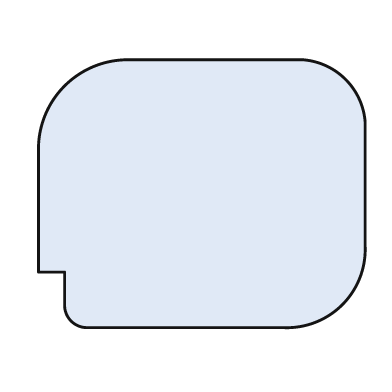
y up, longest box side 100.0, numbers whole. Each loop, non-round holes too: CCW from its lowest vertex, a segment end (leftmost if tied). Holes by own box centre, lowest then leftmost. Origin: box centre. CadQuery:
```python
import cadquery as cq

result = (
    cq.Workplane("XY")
    .moveTo(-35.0, -41.0)
    .lineTo(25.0, -41.0)
    .threePointArc((43.0, -34.0), (50.0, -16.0))
    .lineTo(50.0, 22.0)
    .threePointArc((44.0, 35.0), (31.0, 41.0))
    .lineTo(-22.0, 41.0)
    .threePointArc((-42.0, 33.0), (-50.0, 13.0))
    .lineTo(-50.0, -24.0)
    .lineTo(-42.0, -24.0)
    .lineTo(-42.0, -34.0)
    .threePointArc((-40.0, -39.0), (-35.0, -41.0))
    .close()
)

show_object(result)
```